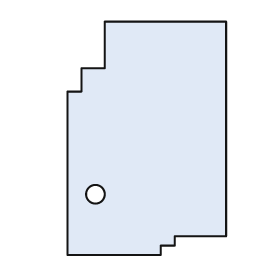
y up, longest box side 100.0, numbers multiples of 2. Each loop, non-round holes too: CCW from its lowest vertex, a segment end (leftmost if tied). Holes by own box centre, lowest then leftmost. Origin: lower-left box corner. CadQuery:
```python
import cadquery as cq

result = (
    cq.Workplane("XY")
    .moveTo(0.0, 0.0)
    .lineTo(40.0, 0.0)
    .lineTo(40.0, 4.0)
    .lineTo(46.0, 4.0)
    .lineTo(46.0, 8.0)
    .lineTo(68.0, 8.0)
    .lineTo(68.0, 100.0)
    .lineTo(16.0, 100.0)
    .lineTo(16.0, 80.0)
    .lineTo(6.0, 80.0)
    .lineTo(6.0, 70.0)
    .lineTo(0.0, 70.0)
    .close()
    .moveTo(12.0, 26.0)
    .circle(4.0)
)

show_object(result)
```